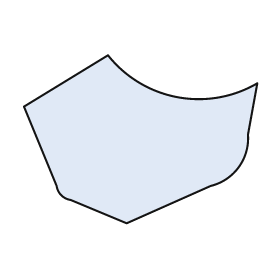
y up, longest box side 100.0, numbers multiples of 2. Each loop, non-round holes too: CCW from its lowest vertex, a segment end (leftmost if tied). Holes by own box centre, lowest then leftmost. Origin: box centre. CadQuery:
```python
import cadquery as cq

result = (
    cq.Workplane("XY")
    .moveTo(-6.0, -36.0)
    .lineTo(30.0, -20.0)
    .threePointArc((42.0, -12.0), (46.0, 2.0))
    .lineTo(50.0, 24.0)
    .threePointArc((16.0, 18.0), (-14.0, 36.0))
    .lineTo(-50.0, 14.0)
    .lineTo(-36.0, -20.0)
    .threePointArc((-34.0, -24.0), (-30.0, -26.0))
    .close()
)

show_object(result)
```